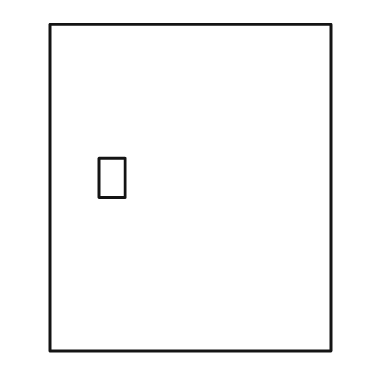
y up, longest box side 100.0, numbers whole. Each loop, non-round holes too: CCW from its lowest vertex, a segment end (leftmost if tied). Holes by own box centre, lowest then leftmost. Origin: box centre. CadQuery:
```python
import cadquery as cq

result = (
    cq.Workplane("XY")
    .moveTo(-43.0, -50.0)
    .lineTo(43.0, -50.0)
    .lineTo(43.0, 50.0)
    .lineTo(-43.0, 50.0)
    .close()
    .moveTo(-28.0, -3.0)
    .lineTo(-20.0, -3.0)
    .lineTo(-20.0, 9.0)
    .lineTo(-28.0, 9.0)
    .close()
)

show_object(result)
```